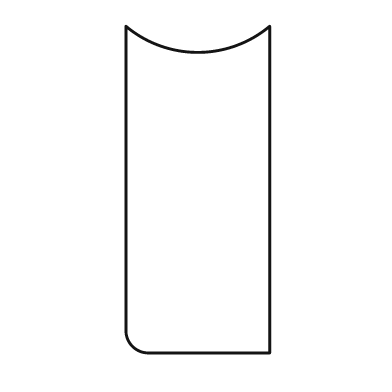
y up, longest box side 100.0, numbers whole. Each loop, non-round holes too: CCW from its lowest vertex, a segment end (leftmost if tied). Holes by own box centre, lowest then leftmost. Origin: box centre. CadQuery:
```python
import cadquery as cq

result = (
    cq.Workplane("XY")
    .moveTo(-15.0, -50.0)
    .lineTo(22.0, -50.0)
    .lineTo(22.0, 50.0)
    .threePointArc((0.0, 42.0), (-22.0, 50.0))
    .lineTo(-22.0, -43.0)
    .threePointArc((-20.0, -48.0), (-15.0, -50.0))
    .close()
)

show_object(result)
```